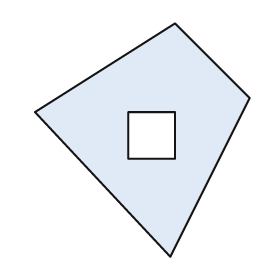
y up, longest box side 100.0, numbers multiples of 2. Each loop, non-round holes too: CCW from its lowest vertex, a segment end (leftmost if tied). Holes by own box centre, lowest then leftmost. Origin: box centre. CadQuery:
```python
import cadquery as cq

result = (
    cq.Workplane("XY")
    .moveTo(12.0, -50.0)
    .lineTo(46.0, 18.0)
    .lineTo(14.0, 50.0)
    .lineTo(-46.0, 12.0)
    .close()
    .moveTo(-6.0, -8.0)
    .lineTo(14.0, -8.0)
    .lineTo(14.0, 12.0)
    .lineTo(-6.0, 12.0)
    .close()
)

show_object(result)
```